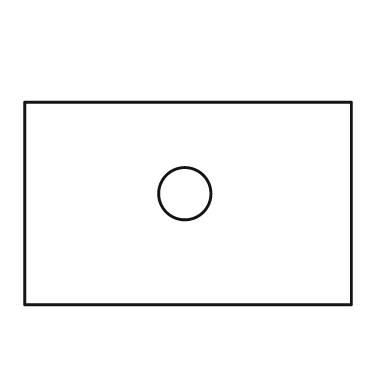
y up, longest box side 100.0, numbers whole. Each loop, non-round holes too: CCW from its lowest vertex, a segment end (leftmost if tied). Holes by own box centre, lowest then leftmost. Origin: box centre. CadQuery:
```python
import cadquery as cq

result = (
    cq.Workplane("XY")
    .moveTo(-50.0, -31.0)
    .lineTo(50.0, -31.0)
    .lineTo(50.0, 31.0)
    .lineTo(-50.0, 31.0)
    .close()
    .moveTo(-1.0, 3.0)
    .circle(8.0)
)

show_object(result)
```